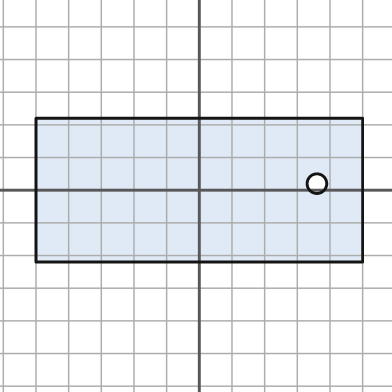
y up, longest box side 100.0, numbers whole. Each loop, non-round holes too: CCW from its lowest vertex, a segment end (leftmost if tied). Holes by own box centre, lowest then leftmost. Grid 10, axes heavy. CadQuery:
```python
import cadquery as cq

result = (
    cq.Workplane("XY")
    .moveTo(-50.0, -22.0)
    .lineTo(50.0, -22.0)
    .lineTo(50.0, 22.0)
    .lineTo(-50.0, 22.0)
    .close()
    .moveTo(36.0, 2.0)
    .circle(3.0)
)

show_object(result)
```